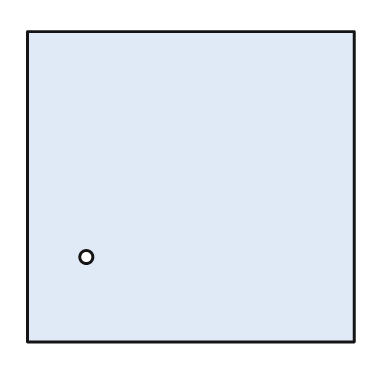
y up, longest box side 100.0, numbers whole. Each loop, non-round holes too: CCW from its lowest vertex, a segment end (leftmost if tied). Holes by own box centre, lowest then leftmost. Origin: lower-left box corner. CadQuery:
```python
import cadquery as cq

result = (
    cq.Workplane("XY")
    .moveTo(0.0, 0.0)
    .lineTo(100.0, 0.0)
    .lineTo(100.0, 95.0)
    .lineTo(0.0, 95.0)
    .close()
    .moveTo(18.0, 26.0)
    .circle(2.0)
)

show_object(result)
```